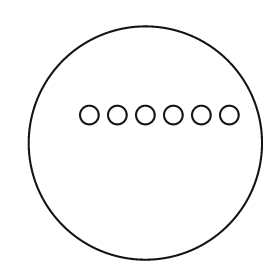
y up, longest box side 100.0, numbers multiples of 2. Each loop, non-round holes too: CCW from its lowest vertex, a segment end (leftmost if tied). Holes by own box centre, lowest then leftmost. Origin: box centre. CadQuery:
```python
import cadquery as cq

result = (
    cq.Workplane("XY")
    .moveTo(0.0, 0.0)
    .circle(50.0)
    .moveTo(-24.0, 12.0)
    .circle(4.0)
    .moveTo(-12.0, 12.0)
    .circle(4.0)
    .moveTo(0.0, 12.0)
    .circle(4.0)
    .moveTo(12.0, 12.0)
    .circle(4.0)
    .moveTo(24.0, 12.0)
    .circle(4.0)
    .moveTo(36.0, 12.0)
    .circle(4.0)
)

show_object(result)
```